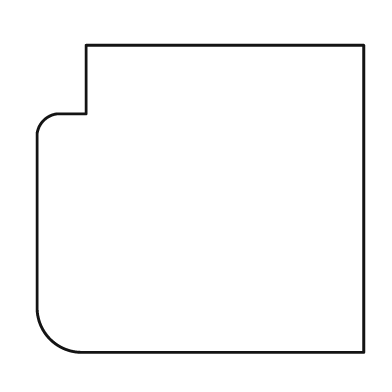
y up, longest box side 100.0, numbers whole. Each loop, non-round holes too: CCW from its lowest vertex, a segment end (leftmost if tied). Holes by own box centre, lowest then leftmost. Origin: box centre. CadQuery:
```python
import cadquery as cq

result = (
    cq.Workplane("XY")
    .moveTo(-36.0, -47.0)
    .lineTo(50.0, -47.0)
    .lineTo(50.0, 47.0)
    .lineTo(-35.0, 47.0)
    .lineTo(-35.0, 26.0)
    .lineTo(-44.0, 26.0)
    .threePointArc((-48.0, 24.0), (-50.0, 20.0))
    .lineTo(-50.0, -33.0)
    .threePointArc((-46.0, -43.0), (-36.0, -47.0))
    .close()
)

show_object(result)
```